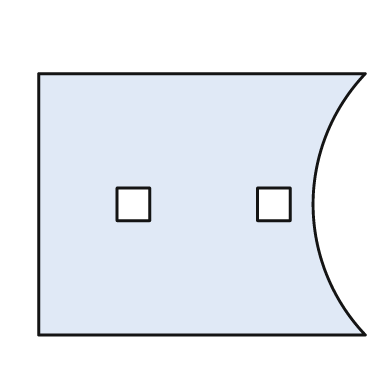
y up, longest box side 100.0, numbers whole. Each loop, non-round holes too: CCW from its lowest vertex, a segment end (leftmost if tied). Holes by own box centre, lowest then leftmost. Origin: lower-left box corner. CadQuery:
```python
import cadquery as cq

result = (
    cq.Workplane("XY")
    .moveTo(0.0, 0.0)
    .lineTo(100.0, 0.0)
    .threePointArc((84.0, 40.0), (100.0, 80.0))
    .lineTo(0.0, 80.0)
    .close()
    .moveTo(24.0, 35.0)
    .lineTo(34.0, 35.0)
    .lineTo(34.0, 45.0)
    .lineTo(24.0, 45.0)
    .close()
    .moveTo(67.0, 35.0)
    .lineTo(77.0, 35.0)
    .lineTo(77.0, 45.0)
    .lineTo(67.0, 45.0)
    .close()
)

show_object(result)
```